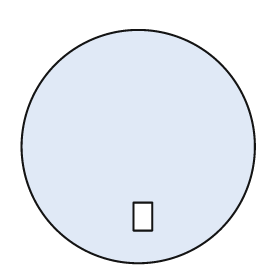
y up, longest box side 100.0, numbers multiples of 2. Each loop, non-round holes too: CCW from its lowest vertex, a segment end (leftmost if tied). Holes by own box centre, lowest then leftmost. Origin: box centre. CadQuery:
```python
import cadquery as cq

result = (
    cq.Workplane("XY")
    .moveTo(0.0, 0.0)
    .circle(50.0)
    .moveTo(-2.0, -36.0)
    .lineTo(6.0, -36.0)
    .lineTo(6.0, -24.0)
    .lineTo(-2.0, -24.0)
    .close()
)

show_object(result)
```